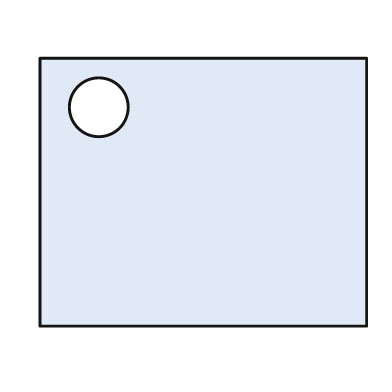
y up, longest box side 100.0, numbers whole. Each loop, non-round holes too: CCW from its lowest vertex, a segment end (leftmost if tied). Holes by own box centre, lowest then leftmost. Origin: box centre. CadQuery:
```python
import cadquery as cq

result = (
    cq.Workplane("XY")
    .moveTo(-50.0, -41.0)
    .lineTo(50.0, -41.0)
    .lineTo(50.0, 41.0)
    .lineTo(-50.0, 41.0)
    .close()
    .moveTo(-32.0, 26.0)
    .circle(9.0)
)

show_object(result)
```